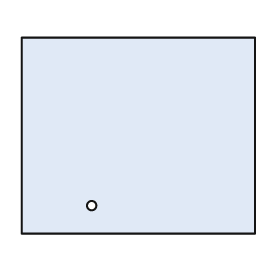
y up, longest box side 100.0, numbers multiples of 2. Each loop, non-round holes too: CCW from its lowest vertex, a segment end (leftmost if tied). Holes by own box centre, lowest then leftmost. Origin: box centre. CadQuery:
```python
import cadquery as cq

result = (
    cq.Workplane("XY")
    .moveTo(-50.0, -42.0)
    .lineTo(50.0, -42.0)
    .lineTo(50.0, 42.0)
    .lineTo(-50.0, 42.0)
    .close()
    .moveTo(-20.0, -30.0)
    .circle(2.0)
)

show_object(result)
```